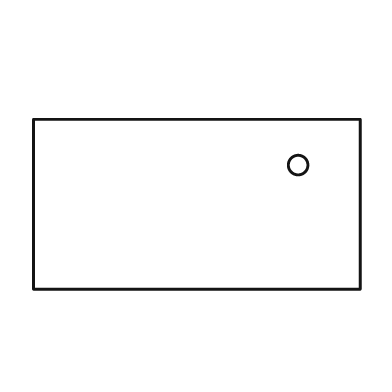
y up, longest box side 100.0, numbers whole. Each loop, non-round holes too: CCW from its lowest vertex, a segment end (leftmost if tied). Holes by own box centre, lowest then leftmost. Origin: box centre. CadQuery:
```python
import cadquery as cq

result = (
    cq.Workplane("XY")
    .moveTo(-50.0, -26.0)
    .lineTo(50.0, -26.0)
    .lineTo(50.0, 26.0)
    .lineTo(-50.0, 26.0)
    .close()
    .moveTo(31.0, 12.0)
    .circle(3.0)
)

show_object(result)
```